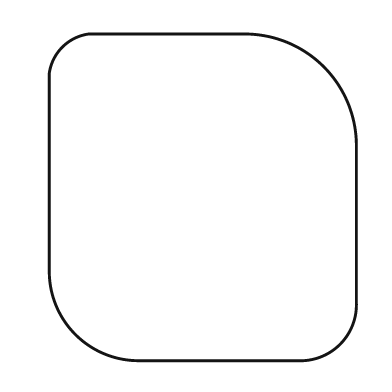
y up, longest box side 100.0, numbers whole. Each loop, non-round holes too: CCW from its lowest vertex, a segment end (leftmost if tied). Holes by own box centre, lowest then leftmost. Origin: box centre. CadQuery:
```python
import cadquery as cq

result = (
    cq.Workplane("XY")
    .moveTo(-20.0, -50.0)
    .lineTo(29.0, -50.0)
    .threePointArc((42.0, -45.0), (47.0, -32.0))
    .lineTo(47.0, 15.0)
    .threePointArc((37.0, 40.0), (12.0, 50.0))
    .lineTo(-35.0, 50.0)
    .threePointArc((-43.0, 46.0), (-47.0, 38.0))
    .lineTo(-47.0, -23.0)
    .threePointArc((-39.0, -42.0), (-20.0, -50.0))
    .close()
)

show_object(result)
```